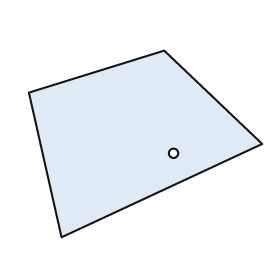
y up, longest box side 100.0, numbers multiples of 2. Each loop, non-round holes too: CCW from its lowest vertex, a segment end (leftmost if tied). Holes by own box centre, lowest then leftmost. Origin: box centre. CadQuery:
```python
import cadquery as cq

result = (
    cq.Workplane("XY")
    .moveTo(-36.0, -40.0)
    .lineTo(50.0, 0.0)
    .lineTo(8.0, 40.0)
    .lineTo(-50.0, 22.0)
    .close()
    .moveTo(12.0, -4.0)
    .circle(2.0)
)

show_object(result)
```